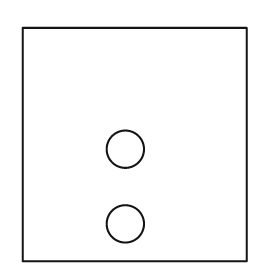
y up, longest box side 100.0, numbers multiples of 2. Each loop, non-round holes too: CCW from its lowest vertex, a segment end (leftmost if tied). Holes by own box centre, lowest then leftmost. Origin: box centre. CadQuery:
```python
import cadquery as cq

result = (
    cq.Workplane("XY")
    .moveTo(-48.0, -50.0)
    .lineTo(48.0, -50.0)
    .lineTo(48.0, 50.0)
    .lineTo(-48.0, 50.0)
    .close()
    .moveTo(-4.0, -34.0)
    .circle(8.0)
    .moveTo(-4.0, -2.0)
    .circle(8.0)
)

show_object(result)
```